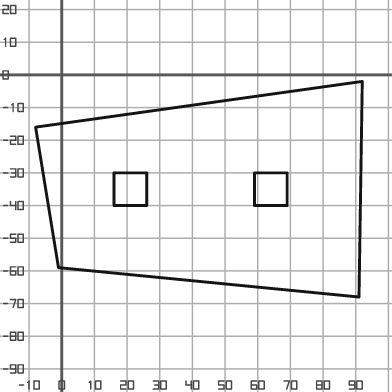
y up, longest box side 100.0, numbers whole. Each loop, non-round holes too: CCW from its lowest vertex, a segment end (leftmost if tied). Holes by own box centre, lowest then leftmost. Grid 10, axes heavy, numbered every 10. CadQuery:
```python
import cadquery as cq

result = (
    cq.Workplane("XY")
    .moveTo(91.0, -68.0)
    .lineTo(92.0, -2.0)
    .lineTo(-8.0, -16.0)
    .lineTo(-1.0, -59.0)
    .close()
    .moveTo(16.0, -40.0)
    .lineTo(26.0, -40.0)
    .lineTo(26.0, -30.0)
    .lineTo(16.0, -30.0)
    .close()
    .moveTo(59.0, -40.0)
    .lineTo(69.0, -40.0)
    .lineTo(69.0, -30.0)
    .lineTo(59.0, -30.0)
    .close()
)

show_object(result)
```